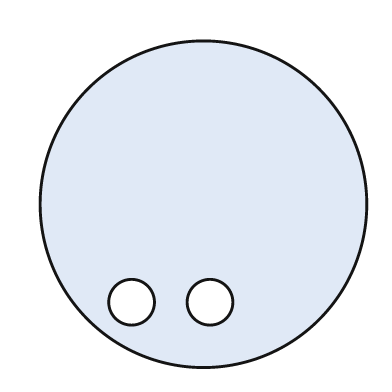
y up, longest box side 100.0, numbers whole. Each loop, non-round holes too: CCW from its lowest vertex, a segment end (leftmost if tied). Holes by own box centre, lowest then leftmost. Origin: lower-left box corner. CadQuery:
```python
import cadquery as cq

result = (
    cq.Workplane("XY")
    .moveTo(50.0, 50.0)
    .circle(50.0)
    .moveTo(28.0, 20.0)
    .circle(7.0)
    .moveTo(52.0, 20.0)
    .circle(7.0)
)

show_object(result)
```